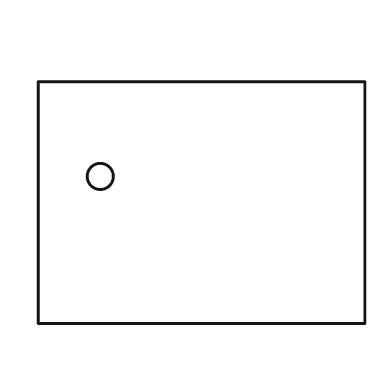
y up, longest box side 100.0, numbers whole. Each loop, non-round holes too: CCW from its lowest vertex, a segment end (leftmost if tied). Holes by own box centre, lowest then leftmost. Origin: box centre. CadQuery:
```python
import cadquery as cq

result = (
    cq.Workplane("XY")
    .moveTo(-50.0, -37.0)
    .lineTo(50.0, -37.0)
    .lineTo(50.0, 37.0)
    .lineTo(-50.0, 37.0)
    .close()
    .moveTo(-31.0, 8.0)
    .circle(4.0)
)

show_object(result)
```